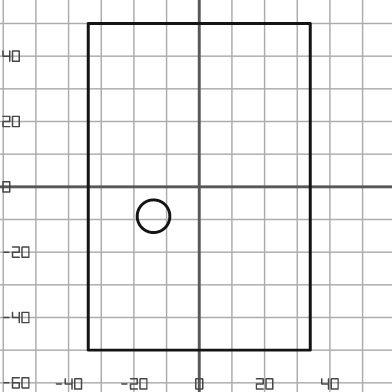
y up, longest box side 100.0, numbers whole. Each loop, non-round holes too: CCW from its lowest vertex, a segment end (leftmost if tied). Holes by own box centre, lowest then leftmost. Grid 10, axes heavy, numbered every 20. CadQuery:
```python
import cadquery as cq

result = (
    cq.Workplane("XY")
    .moveTo(-34.0, -50.0)
    .lineTo(34.0, -50.0)
    .lineTo(34.0, 50.0)
    .lineTo(-34.0, 50.0)
    .close()
    .moveTo(-14.0, -9.0)
    .circle(5.0)
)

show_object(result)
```